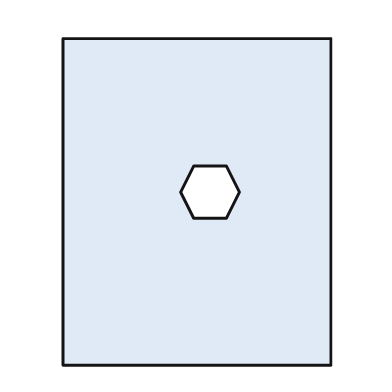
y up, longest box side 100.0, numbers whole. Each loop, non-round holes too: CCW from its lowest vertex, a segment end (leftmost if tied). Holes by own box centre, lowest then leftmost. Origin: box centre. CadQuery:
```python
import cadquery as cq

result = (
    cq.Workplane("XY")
    .moveTo(-41.0, -50.0)
    .lineTo(41.0, -50.0)
    .lineTo(41.0, 50.0)
    .lineTo(-41.0, 50.0)
    .close()
    .moveTo(-1.0, -5.0)
    .lineTo(9.0, -5.0)
    .lineTo(13.0, 3.0)
    .lineTo(9.0, 11.0)
    .lineTo(-1.0, 11.0)
    .lineTo(-5.0, 3.0)
    .close()
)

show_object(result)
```